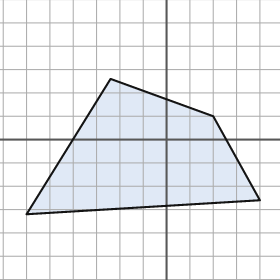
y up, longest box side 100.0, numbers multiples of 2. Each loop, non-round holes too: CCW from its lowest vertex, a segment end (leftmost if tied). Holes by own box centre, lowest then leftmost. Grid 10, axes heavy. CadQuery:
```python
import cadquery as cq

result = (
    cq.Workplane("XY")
    .moveTo(-60.0, -32.0)
    .lineTo(40.0, -26.0)
    .lineTo(20.0, 10.0)
    .lineTo(-24.0, 26.0)
    .close()
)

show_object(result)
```